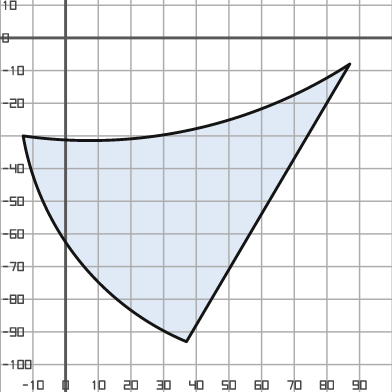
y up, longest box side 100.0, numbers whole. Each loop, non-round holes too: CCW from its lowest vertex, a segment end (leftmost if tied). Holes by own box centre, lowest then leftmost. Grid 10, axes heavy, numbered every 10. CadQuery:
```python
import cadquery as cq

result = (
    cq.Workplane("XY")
    .moveTo(37.0, -93.0)
    .lineTo(87.0, -8.0)
    .threePointArc((39.0, -28.0), (-13.0, -30.0))
    .threePointArc((4.0, -68.0), (37.0, -93.0))
    .close()
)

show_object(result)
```